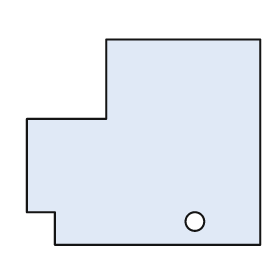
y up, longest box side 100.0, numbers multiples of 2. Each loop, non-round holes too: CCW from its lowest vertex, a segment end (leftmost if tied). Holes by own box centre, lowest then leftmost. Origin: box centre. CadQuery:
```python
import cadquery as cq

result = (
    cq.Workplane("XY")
    .moveTo(-38.0, -44.0)
    .lineTo(50.0, -44.0)
    .lineTo(50.0, 44.0)
    .lineTo(-16.0, 44.0)
    .lineTo(-16.0, 10.0)
    .lineTo(-50.0, 10.0)
    .lineTo(-50.0, -30.0)
    .lineTo(-38.0, -30.0)
    .close()
    .moveTo(22.0, -34.0)
    .circle(4.0)
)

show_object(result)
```